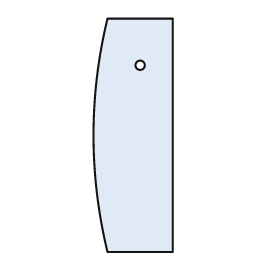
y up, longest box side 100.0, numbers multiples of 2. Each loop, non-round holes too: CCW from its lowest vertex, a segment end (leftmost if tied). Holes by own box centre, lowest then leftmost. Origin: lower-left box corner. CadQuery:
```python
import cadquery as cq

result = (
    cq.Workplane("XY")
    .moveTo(6.0, 0.0)
    .lineTo(34.0, 0.0)
    .lineTo(34.0, 100.0)
    .lineTo(6.0, 100.0)
    .threePointArc((0.0, 50.0), (6.0, 0.0))
    .close()
    .moveTo(20.0, 80.0)
    .circle(2.0)
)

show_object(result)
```